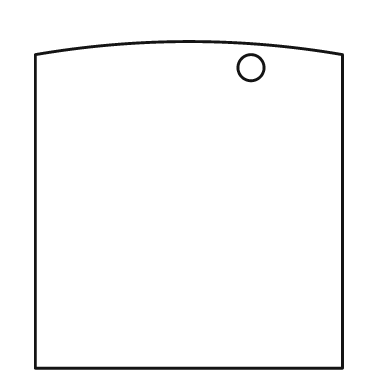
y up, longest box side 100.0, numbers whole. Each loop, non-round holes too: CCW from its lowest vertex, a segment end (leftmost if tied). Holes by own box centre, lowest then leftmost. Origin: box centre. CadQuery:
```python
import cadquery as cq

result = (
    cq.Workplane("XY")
    .moveTo(-47.0, -50.0)
    .lineTo(47.0, -50.0)
    .lineTo(47.0, 46.0)
    .threePointArc((0.0, 50.0), (-47.0, 46.0))
    .close()
    .moveTo(19.0, 42.0)
    .circle(4.0)
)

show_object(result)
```